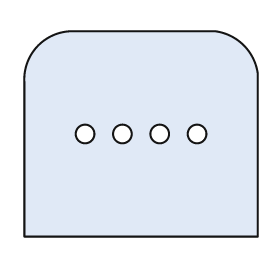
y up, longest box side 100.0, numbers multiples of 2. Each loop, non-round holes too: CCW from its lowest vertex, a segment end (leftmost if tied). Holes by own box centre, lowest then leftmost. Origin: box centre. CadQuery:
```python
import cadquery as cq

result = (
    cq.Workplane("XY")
    .moveTo(-50.0, -44.0)
    .lineTo(50.0, -44.0)
    .lineTo(50.0, 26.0)
    .threePointArc((44.0, 38.0), (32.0, 44.0))
    .lineTo(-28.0, 44.0)
    .threePointArc((-44.0, 38.0), (-50.0, 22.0))
    .close()
    .moveTo(-24.0, 0.0)
    .circle(4.0)
    .moveTo(-8.0, 0.0)
    .circle(4.0)
    .moveTo(8.0, 0.0)
    .circle(4.0)
    .moveTo(24.0, 0.0)
    .circle(4.0)
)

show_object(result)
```